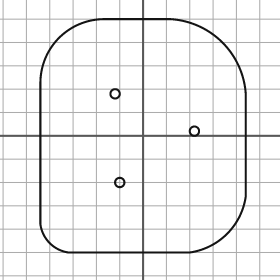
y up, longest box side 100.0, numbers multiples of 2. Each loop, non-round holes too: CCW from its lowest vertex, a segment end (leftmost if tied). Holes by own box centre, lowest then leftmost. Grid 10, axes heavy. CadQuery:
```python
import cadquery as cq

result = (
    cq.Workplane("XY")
    .moveTo(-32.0, -50.0)
    .lineTo(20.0, -50.0)
    .threePointArc((36.0, -42.0), (44.0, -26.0))
    .lineTo(44.0, 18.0)
    .threePointArc((34.0, 40.0), (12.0, 50.0))
    .lineTo(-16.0, 50.0)
    .threePointArc((-36.0, 42.0), (-44.0, 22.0))
    .lineTo(-44.0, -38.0)
    .threePointArc((-40.0, -46.0), (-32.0, -50.0))
    .close()
    .moveTo(-10.0, -20.0)
    .circle(2.0)
    .moveTo(22.0, 2.0)
    .circle(2.0)
    .moveTo(-12.0, 18.0)
    .circle(2.0)
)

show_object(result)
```